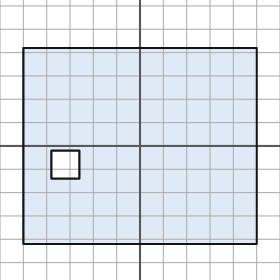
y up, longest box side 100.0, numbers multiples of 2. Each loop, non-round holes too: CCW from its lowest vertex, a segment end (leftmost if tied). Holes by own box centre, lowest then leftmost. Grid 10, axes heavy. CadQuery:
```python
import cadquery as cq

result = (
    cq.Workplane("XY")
    .moveTo(-50.0, -42.0)
    .lineTo(50.0, -42.0)
    .lineTo(50.0, 42.0)
    .lineTo(-50.0, 42.0)
    .close()
    .moveTo(-38.0, -14.0)
    .lineTo(-26.0, -14.0)
    .lineTo(-26.0, -2.0)
    .lineTo(-38.0, -2.0)
    .close()
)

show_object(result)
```